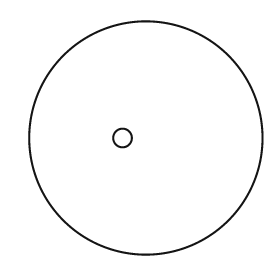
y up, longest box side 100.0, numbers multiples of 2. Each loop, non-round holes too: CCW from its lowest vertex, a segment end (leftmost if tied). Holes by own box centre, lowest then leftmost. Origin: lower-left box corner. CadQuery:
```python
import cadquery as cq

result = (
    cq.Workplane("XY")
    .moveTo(50.0, 50.0)
    .circle(50.0)
    .moveTo(40.0, 50.0)
    .circle(4.0)
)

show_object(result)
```